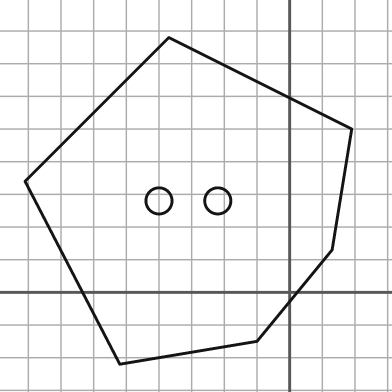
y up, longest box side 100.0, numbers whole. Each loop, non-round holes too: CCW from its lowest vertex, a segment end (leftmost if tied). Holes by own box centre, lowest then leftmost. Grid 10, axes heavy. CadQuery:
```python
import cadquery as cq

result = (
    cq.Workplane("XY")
    .moveTo(-52.0, -22.0)
    .lineTo(-10.0, -15.0)
    .lineTo(13.0, 13.0)
    .lineTo(19.0, 50.0)
    .lineTo(-37.0, 78.0)
    .lineTo(-81.0, 34.0)
    .close()
    .moveTo(-40.0, 28.0)
    .circle(4.0)
    .moveTo(-22.0, 28.0)
    .circle(4.0)
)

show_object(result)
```